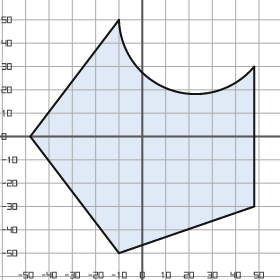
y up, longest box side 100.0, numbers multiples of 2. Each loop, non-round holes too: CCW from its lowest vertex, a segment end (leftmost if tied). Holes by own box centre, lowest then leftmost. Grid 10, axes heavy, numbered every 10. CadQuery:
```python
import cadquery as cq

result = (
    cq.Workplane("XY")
    .moveTo(-10.0, -50.0)
    .lineTo(48.0, -30.0)
    .lineTo(48.0, 30.0)
    .threePointArc((12.0, 20.0), (-10.0, 50.0))
    .lineTo(-48.0, 0.0)
    .close()
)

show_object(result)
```